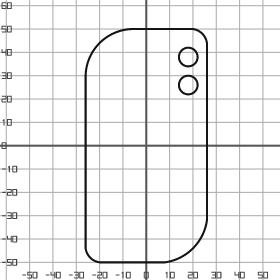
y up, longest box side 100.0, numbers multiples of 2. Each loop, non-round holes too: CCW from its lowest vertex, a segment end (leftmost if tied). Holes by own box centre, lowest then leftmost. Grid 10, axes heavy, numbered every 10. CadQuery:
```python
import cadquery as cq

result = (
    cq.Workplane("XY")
    .moveTo(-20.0, -50.0)
    .lineTo(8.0, -50.0)
    .threePointArc((20.0, -44.0), (26.0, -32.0))
    .lineTo(26.0, 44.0)
    .threePointArc((24.0, 48.0), (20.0, 50.0))
    .lineTo(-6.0, 50.0)
    .threePointArc((-20.0, 44.0), (-26.0, 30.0))
    .lineTo(-26.0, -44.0)
    .threePointArc((-24.0, -48.0), (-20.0, -50.0))
    .close()
    .moveTo(18.0, 26.0)
    .circle(4.0)
    .moveTo(18.0, 38.0)
    .circle(4.0)
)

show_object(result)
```